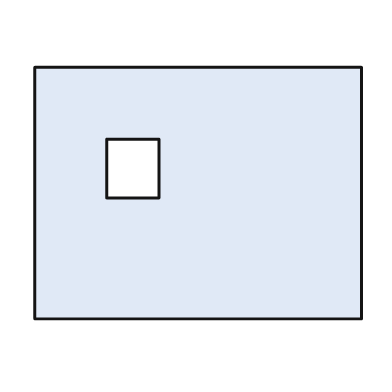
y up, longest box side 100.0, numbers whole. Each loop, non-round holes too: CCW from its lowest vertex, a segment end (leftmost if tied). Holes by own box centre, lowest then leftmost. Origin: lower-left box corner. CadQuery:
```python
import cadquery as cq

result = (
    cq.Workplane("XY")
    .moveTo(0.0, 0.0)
    .lineTo(100.0, 0.0)
    .lineTo(100.0, 77.0)
    .lineTo(0.0, 77.0)
    .close()
    .moveTo(22.0, 37.0)
    .lineTo(38.0, 37.0)
    .lineTo(38.0, 55.0)
    .lineTo(22.0, 55.0)
    .close()
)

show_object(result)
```